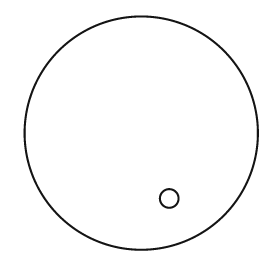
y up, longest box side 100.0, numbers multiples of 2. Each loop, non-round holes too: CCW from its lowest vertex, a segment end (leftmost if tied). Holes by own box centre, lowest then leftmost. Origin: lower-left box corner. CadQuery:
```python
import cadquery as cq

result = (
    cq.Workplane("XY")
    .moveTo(50.0, 50.0)
    .circle(50.0)
    .moveTo(62.0, 22.0)
    .circle(4.0)
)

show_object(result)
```